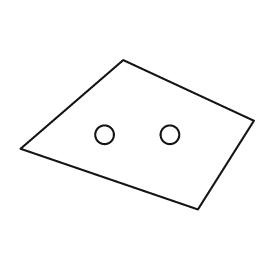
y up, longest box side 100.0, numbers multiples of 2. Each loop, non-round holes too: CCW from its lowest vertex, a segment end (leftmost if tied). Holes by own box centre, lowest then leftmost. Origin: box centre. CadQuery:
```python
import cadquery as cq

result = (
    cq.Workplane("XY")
    .moveTo(26.0, -32.0)
    .lineTo(50.0, 6.0)
    .lineTo(-6.0, 32.0)
    .lineTo(-50.0, -6.0)
    .close()
    .moveTo(-14.0, 0.0)
    .circle(4.0)
    .moveTo(14.0, 0.0)
    .circle(4.0)
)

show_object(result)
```